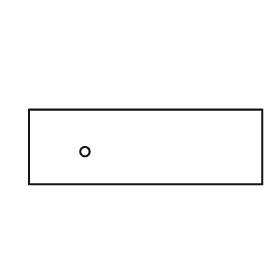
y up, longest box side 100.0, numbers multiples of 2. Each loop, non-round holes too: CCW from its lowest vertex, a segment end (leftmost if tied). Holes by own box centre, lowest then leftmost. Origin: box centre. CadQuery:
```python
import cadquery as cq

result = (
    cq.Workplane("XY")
    .moveTo(-50.0, -16.0)
    .lineTo(50.0, -16.0)
    .lineTo(50.0, 16.0)
    .lineTo(-50.0, 16.0)
    .close()
    .moveTo(-26.0, -2.0)
    .circle(2.0)
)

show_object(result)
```